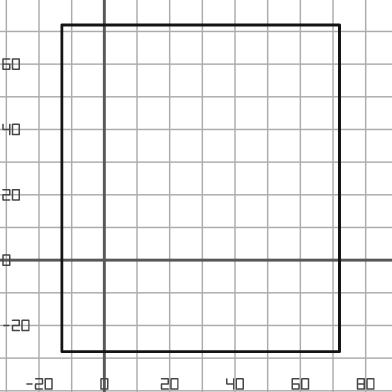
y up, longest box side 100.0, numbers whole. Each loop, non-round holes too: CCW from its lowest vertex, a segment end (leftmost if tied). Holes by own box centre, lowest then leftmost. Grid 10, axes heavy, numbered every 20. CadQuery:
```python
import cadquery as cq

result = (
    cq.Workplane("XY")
    .moveTo(-13.0, -28.0)
    .lineTo(72.0, -28.0)
    .lineTo(72.0, 72.0)
    .lineTo(-13.0, 72.0)
    .close()
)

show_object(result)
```